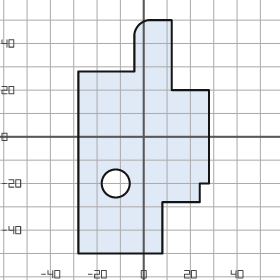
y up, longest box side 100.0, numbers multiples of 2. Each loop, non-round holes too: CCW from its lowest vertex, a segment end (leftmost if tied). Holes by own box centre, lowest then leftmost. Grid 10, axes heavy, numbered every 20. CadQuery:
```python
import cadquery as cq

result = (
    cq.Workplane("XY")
    .moveTo(-28.0, -50.0)
    .lineTo(8.0, -50.0)
    .lineTo(8.0, -28.0)
    .lineTo(24.0, -28.0)
    .lineTo(24.0, -20.0)
    .lineTo(28.0, -20.0)
    .lineTo(28.0, 20.0)
    .lineTo(12.0, 20.0)
    .lineTo(12.0, 50.0)
    .lineTo(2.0, 50.0)
    .threePointArc((-2.0, 48.0), (-4.0, 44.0))
    .lineTo(-4.0, 28.0)
    .lineTo(-28.0, 28.0)
    .close()
    .moveTo(-12.0, -20.0)
    .circle(6.0)
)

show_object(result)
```